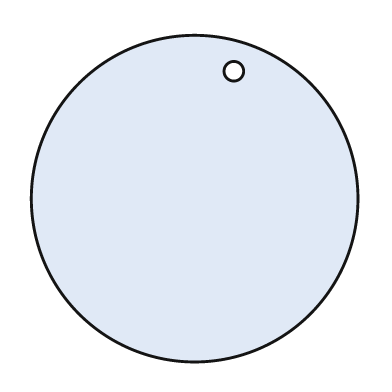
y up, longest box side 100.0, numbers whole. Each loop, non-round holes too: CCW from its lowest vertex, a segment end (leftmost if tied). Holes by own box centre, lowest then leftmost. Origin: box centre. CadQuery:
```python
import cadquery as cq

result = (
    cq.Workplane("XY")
    .moveTo(0.0, 0.0)
    .circle(50.0)
    .moveTo(12.0, 39.0)
    .circle(3.0)
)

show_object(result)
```